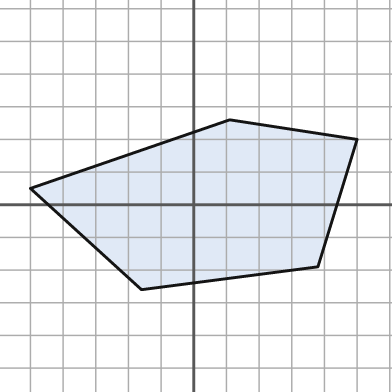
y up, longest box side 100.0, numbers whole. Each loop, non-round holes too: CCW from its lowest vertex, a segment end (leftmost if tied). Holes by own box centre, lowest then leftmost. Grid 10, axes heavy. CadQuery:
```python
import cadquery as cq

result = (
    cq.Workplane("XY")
    .moveTo(-16.0, -26.0)
    .lineTo(38.0, -19.0)
    .lineTo(50.0, 20.0)
    .lineTo(11.0, 26.0)
    .lineTo(-50.0, 5.0)
    .close()
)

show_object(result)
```